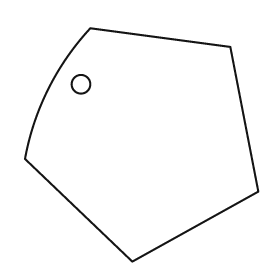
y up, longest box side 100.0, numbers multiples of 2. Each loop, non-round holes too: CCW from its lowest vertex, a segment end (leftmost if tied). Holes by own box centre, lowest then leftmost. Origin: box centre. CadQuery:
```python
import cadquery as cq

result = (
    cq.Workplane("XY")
    .moveTo(-4.0, -50.0)
    .lineTo(50.0, -20.0)
    .lineTo(38.0, 42.0)
    .lineTo(-22.0, 50.0)
    .threePointArc((-40.0, 24.0), (-50.0, -6.0))
    .close()
    .moveTo(-26.0, 26.0)
    .circle(4.0)
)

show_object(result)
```